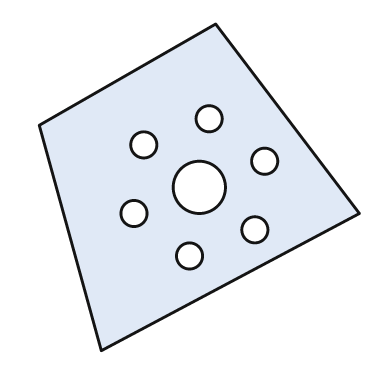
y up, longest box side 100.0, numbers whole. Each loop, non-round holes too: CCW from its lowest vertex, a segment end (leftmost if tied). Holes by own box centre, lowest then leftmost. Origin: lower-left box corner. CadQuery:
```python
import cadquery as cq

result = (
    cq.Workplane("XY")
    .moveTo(19.0, 0.0)
    .lineTo(98.0, 42.0)
    .lineTo(54.0, 100.0)
    .lineTo(0.0, 69.0)
    .close()
    .moveTo(46.0, 29.0)
    .circle(4.0)
    .moveTo(66.0, 37.0)
    .circle(4.0)
    .moveTo(29.0, 42.0)
    .circle(4.0)
    .moveTo(49.0, 50.0)
    .circle(8.0)
    .moveTo(69.0, 58.0)
    .circle(4.0)
    .moveTo(32.0, 63.0)
    .circle(4.0)
    .moveTo(52.0, 71.0)
    .circle(4.0)
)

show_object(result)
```